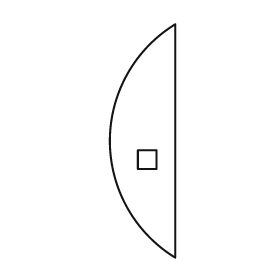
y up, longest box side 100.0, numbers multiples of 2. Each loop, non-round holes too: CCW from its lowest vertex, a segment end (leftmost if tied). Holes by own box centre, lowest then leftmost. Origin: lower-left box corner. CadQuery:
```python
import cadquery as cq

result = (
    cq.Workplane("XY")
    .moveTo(28.0, 0.0)
    .lineTo(28.0, 100.0)
    .threePointArc((0.0, 50.0), (28.0, 0.0))
    .close()
    .moveTo(12.0, 38.0)
    .lineTo(20.0, 38.0)
    .lineTo(20.0, 46.0)
    .lineTo(12.0, 46.0)
    .close()
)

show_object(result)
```